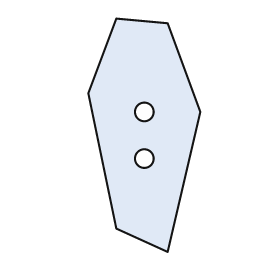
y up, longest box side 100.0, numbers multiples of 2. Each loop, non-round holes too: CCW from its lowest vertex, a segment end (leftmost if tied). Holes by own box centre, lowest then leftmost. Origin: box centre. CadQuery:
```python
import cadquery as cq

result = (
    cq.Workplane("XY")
    .moveTo(10.0, -50.0)
    .lineTo(24.0, 10.0)
    .lineTo(10.0, 48.0)
    .lineTo(-12.0, 50.0)
    .lineTo(-24.0, 18.0)
    .lineTo(-12.0, -40.0)
    .close()
    .moveTo(0.0, -10.0)
    .circle(4.0)
    .moveTo(0.0, 10.0)
    .circle(4.0)
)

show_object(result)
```